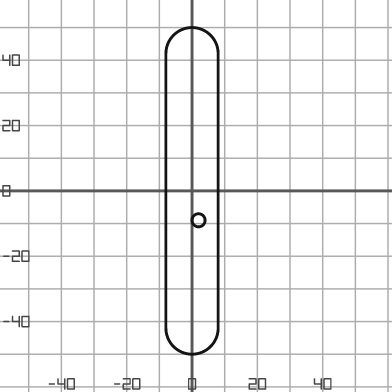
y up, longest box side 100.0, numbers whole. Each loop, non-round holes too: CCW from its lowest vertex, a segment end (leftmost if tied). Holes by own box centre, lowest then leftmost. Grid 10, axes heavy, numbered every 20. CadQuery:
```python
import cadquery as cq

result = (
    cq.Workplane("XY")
    .moveTo(-8.0, -42.0)
    .threePointArc((0.0, -50.0), (8.0, -42.0))
    .lineTo(8.0, 42.0)
    .threePointArc((0.0, 50.0), (-8.0, 42.0))
    .close()
    .moveTo(2.0, -9.0)
    .circle(2.0)
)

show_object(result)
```